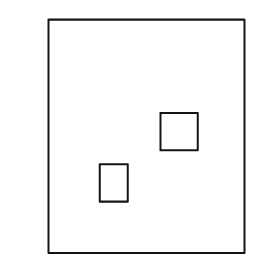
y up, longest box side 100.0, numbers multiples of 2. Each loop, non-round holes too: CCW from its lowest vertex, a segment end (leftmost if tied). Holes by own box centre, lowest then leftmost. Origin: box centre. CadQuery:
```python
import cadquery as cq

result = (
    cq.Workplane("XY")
    .moveTo(-42.0, -50.0)
    .lineTo(42.0, -50.0)
    .lineTo(42.0, 50.0)
    .lineTo(-42.0, 50.0)
    .close()
    .moveTo(-20.0, -28.0)
    .lineTo(-8.0, -28.0)
    .lineTo(-8.0, -12.0)
    .lineTo(-20.0, -12.0)
    .close()
    .moveTo(6.0, -6.0)
    .lineTo(22.0, -6.0)
    .lineTo(22.0, 10.0)
    .lineTo(6.0, 10.0)
    .close()
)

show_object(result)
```